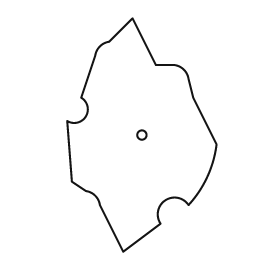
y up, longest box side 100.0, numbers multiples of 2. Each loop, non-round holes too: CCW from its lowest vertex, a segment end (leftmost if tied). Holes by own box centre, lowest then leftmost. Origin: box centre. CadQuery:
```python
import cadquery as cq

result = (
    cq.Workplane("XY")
    .moveTo(-8.0, -50.0)
    .lineTo(8.0, -38.0)
    .threePointArc((10.0, -28.0), (20.0, -30.0))
    .threePointArc((28.0, -18.0), (32.0, -4.0))
    .lineTo(22.0, 16.0)
    .lineTo(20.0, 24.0)
    .threePointArc((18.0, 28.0), (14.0, 30.0))
    .lineTo(6.0, 30.0)
    .lineTo(-4.0, 50.0)
    .lineTo(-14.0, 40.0)
    .threePointArc((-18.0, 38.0), (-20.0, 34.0))
    .lineTo(-26.0, 16.0)
    .threePointArc((-24.0, 8.0), (-32.0, 6.0))
    .lineTo(-30.0, -20.0)
    .lineTo(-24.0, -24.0)
    .threePointArc((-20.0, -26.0), (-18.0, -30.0))
    .close()
    .moveTo(0.0, 0.0)
    .circle(2.0)
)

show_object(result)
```